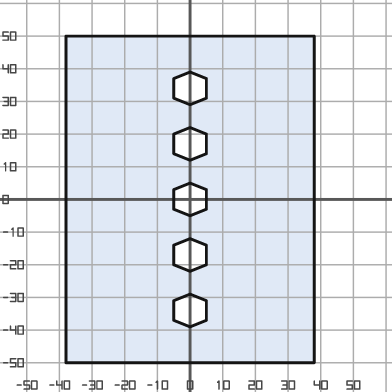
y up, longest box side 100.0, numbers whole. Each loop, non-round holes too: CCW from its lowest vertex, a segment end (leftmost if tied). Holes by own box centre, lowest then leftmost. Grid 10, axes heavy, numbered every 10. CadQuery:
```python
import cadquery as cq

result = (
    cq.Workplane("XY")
    .moveTo(-38.0, -50.0)
    .lineTo(38.0, -50.0)
    .lineTo(38.0, 50.0)
    .lineTo(-38.0, 50.0)
    .close()
    .moveTo(0.0, -39.0)
    .lineTo(5.0, -37.0)
    .lineTo(5.0, -31.0)
    .lineTo(0.0, -29.0)
    .lineTo(-5.0, -31.0)
    .lineTo(-5.0, -37.0)
    .close()
    .moveTo(0.0, -22.0)
    .lineTo(5.0, -20.0)
    .lineTo(5.0, -14.0)
    .lineTo(0.0, -12.0)
    .lineTo(-5.0, -14.0)
    .lineTo(-5.0, -20.0)
    .close()
    .moveTo(0.0, -5.0)
    .lineTo(5.0, -3.0)
    .lineTo(5.0, 3.0)
    .lineTo(0.0, 5.0)
    .lineTo(-5.0, 3.0)
    .lineTo(-5.0, -3.0)
    .close()
    .moveTo(0.0, 12.0)
    .lineTo(5.0, 14.0)
    .lineTo(5.0, 20.0)
    .lineTo(0.0, 22.0)
    .lineTo(-5.0, 20.0)
    .lineTo(-5.0, 14.0)
    .close()
    .moveTo(0.0, 29.0)
    .lineTo(5.0, 31.0)
    .lineTo(5.0, 37.0)
    .lineTo(0.0, 39.0)
    .lineTo(-5.0, 37.0)
    .lineTo(-5.0, 31.0)
    .close()
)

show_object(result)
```